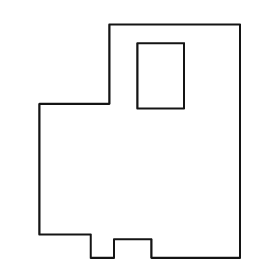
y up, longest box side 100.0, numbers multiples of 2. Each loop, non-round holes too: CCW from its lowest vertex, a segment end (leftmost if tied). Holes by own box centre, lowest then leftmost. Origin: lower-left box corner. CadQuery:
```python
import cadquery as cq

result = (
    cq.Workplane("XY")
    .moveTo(22.0, 0.0)
    .lineTo(32.0, 0.0)
    .lineTo(32.0, 8.0)
    .lineTo(48.0, 8.0)
    .lineTo(48.0, 0.0)
    .lineTo(86.0, 0.0)
    .lineTo(86.0, 100.0)
    .lineTo(30.0, 100.0)
    .lineTo(30.0, 66.0)
    .lineTo(0.0, 66.0)
    .lineTo(0.0, 10.0)
    .lineTo(22.0, 10.0)
    .close()
    .moveTo(42.0, 64.0)
    .lineTo(62.0, 64.0)
    .lineTo(62.0, 92.0)
    .lineTo(42.0, 92.0)
    .close()
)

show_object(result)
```